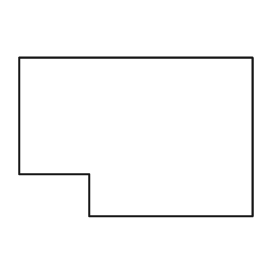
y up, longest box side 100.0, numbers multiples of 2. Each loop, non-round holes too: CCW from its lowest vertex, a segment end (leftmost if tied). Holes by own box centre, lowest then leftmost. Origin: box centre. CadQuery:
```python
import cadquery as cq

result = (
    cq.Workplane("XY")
    .moveTo(-20.0, -34.0)
    .lineTo(50.0, -34.0)
    .lineTo(50.0, 34.0)
    .lineTo(-50.0, 34.0)
    .lineTo(-50.0, -16.0)
    .lineTo(-20.0, -16.0)
    .close()
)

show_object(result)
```